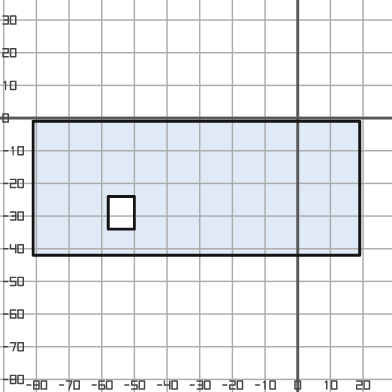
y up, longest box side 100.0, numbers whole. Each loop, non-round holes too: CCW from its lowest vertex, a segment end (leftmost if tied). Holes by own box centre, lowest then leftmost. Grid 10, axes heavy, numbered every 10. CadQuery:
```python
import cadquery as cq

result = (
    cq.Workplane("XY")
    .moveTo(-81.0, -42.0)
    .lineTo(19.0, -42.0)
    .lineTo(19.0, -1.0)
    .lineTo(-81.0, -1.0)
    .close()
    .moveTo(-58.0, -34.0)
    .lineTo(-50.0, -34.0)
    .lineTo(-50.0, -24.0)
    .lineTo(-58.0, -24.0)
    .close()
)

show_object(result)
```